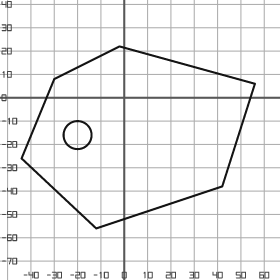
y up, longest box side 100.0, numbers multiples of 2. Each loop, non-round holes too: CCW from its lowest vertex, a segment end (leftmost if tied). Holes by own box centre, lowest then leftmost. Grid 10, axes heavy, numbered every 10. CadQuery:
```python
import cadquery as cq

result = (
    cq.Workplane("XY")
    .moveTo(-12.0, -56.0)
    .lineTo(42.0, -38.0)
    .lineTo(56.0, 6.0)
    .lineTo(-2.0, 22.0)
    .lineTo(-30.0, 8.0)
    .lineTo(-44.0, -26.0)
    .close()
    .moveTo(-20.0, -16.0)
    .circle(6.0)
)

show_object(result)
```